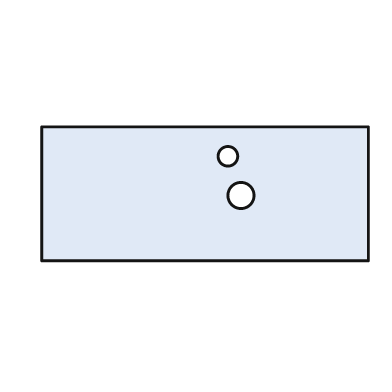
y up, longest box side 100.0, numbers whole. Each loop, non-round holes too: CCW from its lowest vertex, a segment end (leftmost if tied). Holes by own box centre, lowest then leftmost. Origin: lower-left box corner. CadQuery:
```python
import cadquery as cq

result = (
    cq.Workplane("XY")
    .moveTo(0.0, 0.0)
    .lineTo(100.0, 0.0)
    .lineTo(100.0, 41.0)
    .lineTo(0.0, 41.0)
    .close()
    .moveTo(61.0, 20.0)
    .circle(4.0)
    .moveTo(57.0, 32.0)
    .circle(3.0)
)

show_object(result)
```